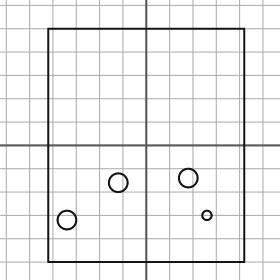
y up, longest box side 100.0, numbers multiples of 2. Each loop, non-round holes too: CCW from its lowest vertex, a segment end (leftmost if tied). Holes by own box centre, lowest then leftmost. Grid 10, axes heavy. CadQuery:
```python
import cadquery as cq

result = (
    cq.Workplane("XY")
    .moveTo(-42.0, -50.0)
    .lineTo(42.0, -50.0)
    .lineTo(42.0, 50.0)
    .lineTo(-42.0, 50.0)
    .close()
    .moveTo(-34.0, -32.0)
    .circle(4.0)
    .moveTo(26.0, -30.0)
    .circle(2.0)
    .moveTo(-12.0, -16.0)
    .circle(4.0)
    .moveTo(18.0, -14.0)
    .circle(4.0)
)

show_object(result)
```